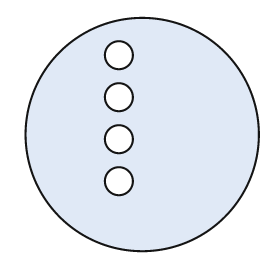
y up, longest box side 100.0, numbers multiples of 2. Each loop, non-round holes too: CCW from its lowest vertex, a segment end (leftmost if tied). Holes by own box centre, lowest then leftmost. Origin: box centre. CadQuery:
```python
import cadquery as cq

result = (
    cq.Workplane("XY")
    .moveTo(0.0, 0.0)
    .circle(50.0)
    .moveTo(-10.0, -20.0)
    .circle(6.0)
    .moveTo(-10.0, -2.0)
    .circle(6.0)
    .moveTo(-10.0, 16.0)
    .circle(6.0)
    .moveTo(-10.0, 34.0)
    .circle(6.0)
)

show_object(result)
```